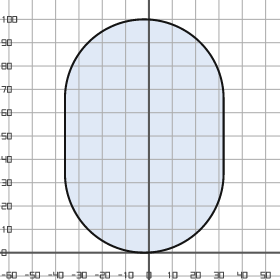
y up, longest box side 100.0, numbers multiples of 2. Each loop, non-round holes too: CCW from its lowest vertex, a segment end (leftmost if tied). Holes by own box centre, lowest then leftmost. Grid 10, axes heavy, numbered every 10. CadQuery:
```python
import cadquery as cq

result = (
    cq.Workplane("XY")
    .moveTo(-36.0, 34.0)
    .threePointArc((-2.0, 0.0), (32.0, 34.0))
    .lineTo(32.0, 66.0)
    .threePointArc((-2.0, 100.0), (-36.0, 66.0))
    .close()
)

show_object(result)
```